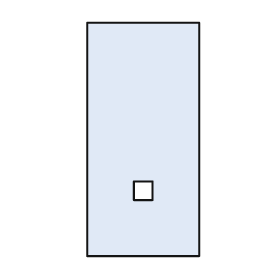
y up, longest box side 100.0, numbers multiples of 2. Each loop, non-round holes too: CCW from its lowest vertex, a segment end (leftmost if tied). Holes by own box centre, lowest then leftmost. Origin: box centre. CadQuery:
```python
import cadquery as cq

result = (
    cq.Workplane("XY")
    .moveTo(-24.0, -50.0)
    .lineTo(24.0, -50.0)
    .lineTo(24.0, 50.0)
    .lineTo(-24.0, 50.0)
    .close()
    .moveTo(-4.0, -26.0)
    .lineTo(4.0, -26.0)
    .lineTo(4.0, -18.0)
    .lineTo(-4.0, -18.0)
    .close()
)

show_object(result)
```